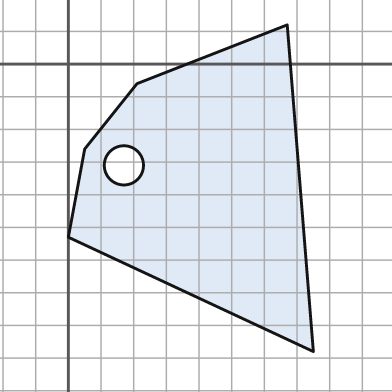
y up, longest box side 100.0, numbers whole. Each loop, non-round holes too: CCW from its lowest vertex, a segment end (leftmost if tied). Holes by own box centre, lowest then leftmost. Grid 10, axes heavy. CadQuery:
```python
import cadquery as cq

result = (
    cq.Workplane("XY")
    .moveTo(75.0, -88.0)
    .lineTo(67.0, 12.0)
    .lineTo(21.0, -6.0)
    .lineTo(5.0, -26.0)
    .lineTo(0.0, -53.0)
    .close()
    .moveTo(17.0, -31.0)
    .circle(6.0)
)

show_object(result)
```